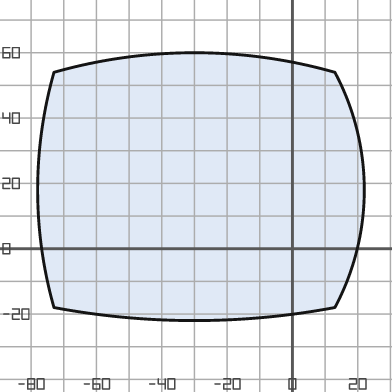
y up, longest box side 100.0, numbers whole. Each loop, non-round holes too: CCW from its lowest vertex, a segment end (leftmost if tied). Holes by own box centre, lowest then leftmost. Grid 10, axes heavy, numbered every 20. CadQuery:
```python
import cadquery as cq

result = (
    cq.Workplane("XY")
    .moveTo(-73.0, -18.0)
    .threePointArc((-30.0, -22.0), (13.0, -18.0))
    .threePointArc((22.0, 18.0), (13.0, 54.0))
    .threePointArc((-30.0, 60.0), (-73.0, 54.0))
    .threePointArc((-78.0, 18.0), (-73.0, -18.0))
    .close()
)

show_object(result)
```